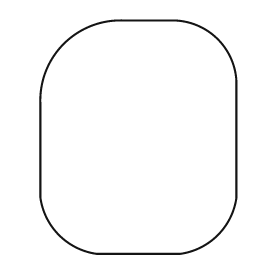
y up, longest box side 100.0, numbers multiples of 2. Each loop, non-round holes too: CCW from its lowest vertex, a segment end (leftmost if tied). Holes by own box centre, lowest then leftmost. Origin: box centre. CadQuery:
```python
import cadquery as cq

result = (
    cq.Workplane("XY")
    .moveTo(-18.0, -50.0)
    .lineTo(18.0, -50.0)
    .threePointArc((34.0, -42.0), (42.0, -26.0))
    .lineTo(42.0, 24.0)
    .threePointArc((34.0, 42.0), (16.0, 50.0))
    .lineTo(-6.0, 50.0)
    .threePointArc((-32.0, 40.0), (-42.0, 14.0))
    .lineTo(-42.0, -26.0)
    .threePointArc((-34.0, -42.0), (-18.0, -50.0))
    .close()
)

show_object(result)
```